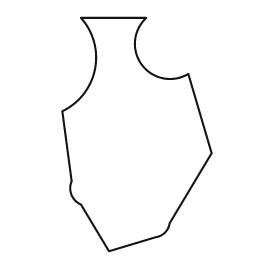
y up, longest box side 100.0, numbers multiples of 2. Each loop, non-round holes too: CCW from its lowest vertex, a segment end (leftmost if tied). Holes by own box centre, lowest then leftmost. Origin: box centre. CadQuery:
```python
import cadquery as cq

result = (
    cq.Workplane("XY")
    .moveTo(-12.0, -50.0)
    .lineTo(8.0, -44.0)
    .threePointArc((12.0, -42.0), (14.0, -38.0))
    .lineTo(32.0, -8.0)
    .lineTo(22.0, 26.0)
    .threePointArc((2.0, 30.0), (4.0, 50.0))
    .lineTo(-24.0, 50.0)
    .threePointArc((-18.0, 28.0), (-32.0, 10.0))
    .lineTo(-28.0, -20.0)
    .threePointArc((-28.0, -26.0), (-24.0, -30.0))
    .close()
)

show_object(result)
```